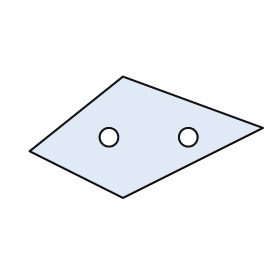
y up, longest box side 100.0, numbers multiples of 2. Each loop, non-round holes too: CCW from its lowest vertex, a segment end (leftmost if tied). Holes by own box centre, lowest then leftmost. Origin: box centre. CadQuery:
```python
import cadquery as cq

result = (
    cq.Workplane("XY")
    .moveTo(-10.0, -26.0)
    .lineTo(50.0, 4.0)
    .lineTo(-10.0, 26.0)
    .lineTo(-50.0, -6.0)
    .close()
    .moveTo(-16.0, 0.0)
    .circle(4.0)
    .moveTo(18.0, 0.0)
    .circle(4.0)
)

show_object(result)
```